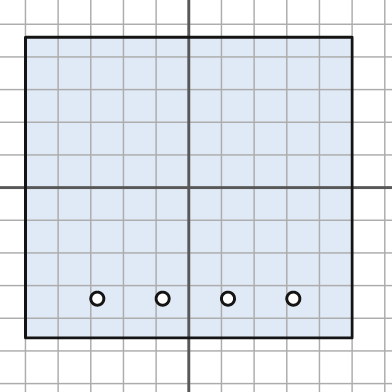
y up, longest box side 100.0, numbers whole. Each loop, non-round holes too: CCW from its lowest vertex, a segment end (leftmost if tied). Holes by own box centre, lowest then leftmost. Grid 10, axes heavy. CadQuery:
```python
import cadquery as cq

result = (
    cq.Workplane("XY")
    .moveTo(-50.0, -46.0)
    .lineTo(50.0, -46.0)
    .lineTo(50.0, 46.0)
    .lineTo(-50.0, 46.0)
    .close()
    .moveTo(-28.0, -34.0)
    .circle(2.0)
    .moveTo(-8.0, -34.0)
    .circle(2.0)
    .moveTo(12.0, -34.0)
    .circle(2.0)
    .moveTo(32.0, -34.0)
    .circle(2.0)
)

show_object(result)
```